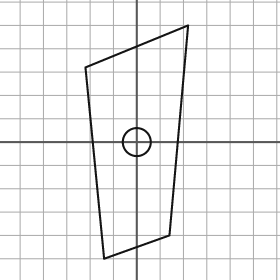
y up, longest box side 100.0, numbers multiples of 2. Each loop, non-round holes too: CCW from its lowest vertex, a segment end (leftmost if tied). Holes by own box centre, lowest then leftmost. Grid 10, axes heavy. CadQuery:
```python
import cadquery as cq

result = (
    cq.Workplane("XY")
    .moveTo(-14.0, -50.0)
    .lineTo(14.0, -40.0)
    .lineTo(22.0, 50.0)
    .lineTo(-22.0, 32.0)
    .close()
    .moveTo(0.0, 0.0)
    .circle(6.0)
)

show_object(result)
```